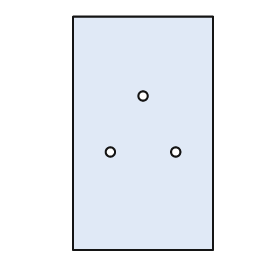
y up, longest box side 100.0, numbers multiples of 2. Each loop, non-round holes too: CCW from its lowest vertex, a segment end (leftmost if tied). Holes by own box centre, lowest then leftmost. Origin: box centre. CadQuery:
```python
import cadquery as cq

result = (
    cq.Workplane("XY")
    .moveTo(-30.0, -50.0)
    .lineTo(30.0, -50.0)
    .lineTo(30.0, 50.0)
    .lineTo(-30.0, 50.0)
    .close()
    .moveTo(-14.0, -8.0)
    .circle(2.0)
    .moveTo(14.0, -8.0)
    .circle(2.0)
    .moveTo(0.0, 16.0)
    .circle(2.0)
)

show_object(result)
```